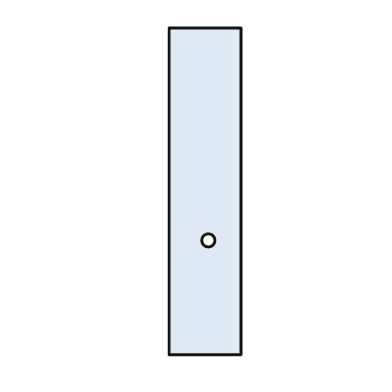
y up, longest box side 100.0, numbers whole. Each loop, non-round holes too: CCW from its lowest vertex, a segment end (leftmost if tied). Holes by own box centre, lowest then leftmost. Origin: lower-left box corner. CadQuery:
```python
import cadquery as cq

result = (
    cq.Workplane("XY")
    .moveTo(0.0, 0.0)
    .lineTo(22.0, 0.0)
    .lineTo(22.0, 100.0)
    .lineTo(0.0, 100.0)
    .close()
    .moveTo(12.0, 35.0)
    .circle(2.0)
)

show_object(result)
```